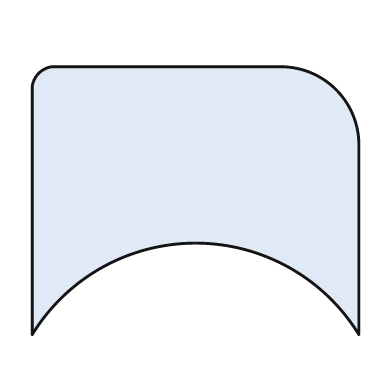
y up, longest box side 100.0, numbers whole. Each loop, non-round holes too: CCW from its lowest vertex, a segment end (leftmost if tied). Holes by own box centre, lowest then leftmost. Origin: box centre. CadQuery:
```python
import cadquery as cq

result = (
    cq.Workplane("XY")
    .moveTo(-50.0, -41.0)
    .threePointArc((0.0, -13.0), (50.0, -41.0))
    .lineTo(50.0, 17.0)
    .threePointArc((43.0, 34.0), (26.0, 41.0))
    .lineTo(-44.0, 41.0)
    .threePointArc((-48.0, 39.0), (-50.0, 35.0))
    .close()
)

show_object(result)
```